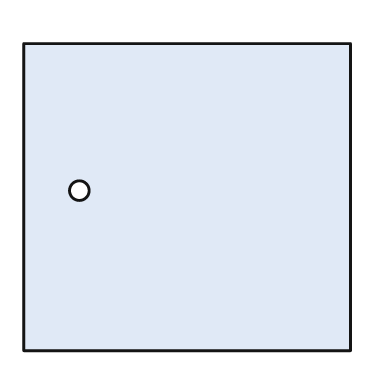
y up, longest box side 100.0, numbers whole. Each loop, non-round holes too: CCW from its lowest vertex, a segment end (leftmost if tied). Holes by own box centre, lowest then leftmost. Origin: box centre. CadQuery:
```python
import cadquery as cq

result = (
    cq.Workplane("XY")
    .moveTo(-50.0, -47.0)
    .lineTo(50.0, -47.0)
    .lineTo(50.0, 47.0)
    .lineTo(-50.0, 47.0)
    .close()
    .moveTo(-33.0, 2.0)
    .circle(3.0)
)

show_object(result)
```